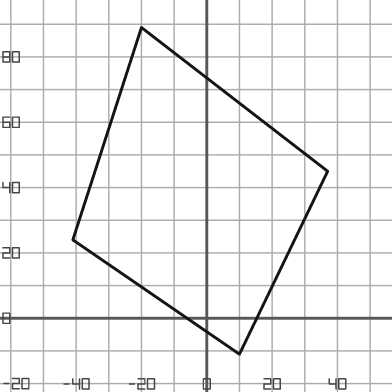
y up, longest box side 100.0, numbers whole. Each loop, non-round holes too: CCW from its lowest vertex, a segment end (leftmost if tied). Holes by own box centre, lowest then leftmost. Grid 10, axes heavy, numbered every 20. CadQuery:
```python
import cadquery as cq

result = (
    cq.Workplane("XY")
    .moveTo(10.0, -11.0)
    .lineTo(37.0, 45.0)
    .lineTo(-20.0, 89.0)
    .lineTo(-41.0, 24.0)
    .close()
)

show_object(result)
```